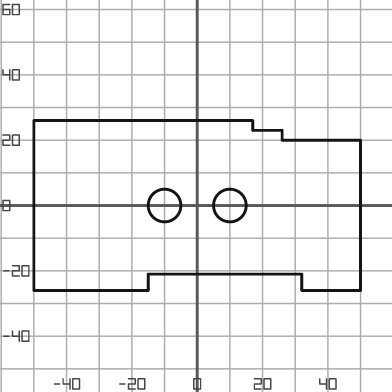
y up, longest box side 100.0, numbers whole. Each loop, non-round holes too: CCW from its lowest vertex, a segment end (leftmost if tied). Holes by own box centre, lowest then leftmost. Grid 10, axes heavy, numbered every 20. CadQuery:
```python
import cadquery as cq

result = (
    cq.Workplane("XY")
    .moveTo(-50.0, -26.0)
    .lineTo(-15.0, -26.0)
    .lineTo(-15.0, -21.0)
    .lineTo(32.0, -21.0)
    .lineTo(32.0, -26.0)
    .lineTo(50.0, -26.0)
    .lineTo(50.0, 20.0)
    .lineTo(26.0, 20.0)
    .lineTo(26.0, 23.0)
    .lineTo(17.0, 23.0)
    .lineTo(17.0, 26.0)
    .lineTo(-50.0, 26.0)
    .close()
    .moveTo(-10.0, 0.0)
    .circle(5.0)
    .moveTo(10.0, 0.0)
    .circle(5.0)
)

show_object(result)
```